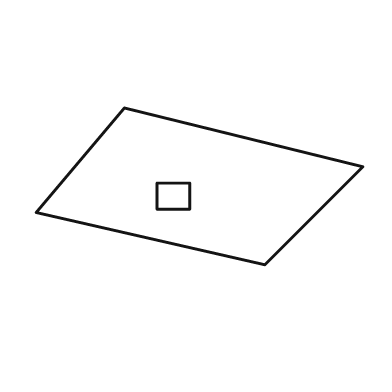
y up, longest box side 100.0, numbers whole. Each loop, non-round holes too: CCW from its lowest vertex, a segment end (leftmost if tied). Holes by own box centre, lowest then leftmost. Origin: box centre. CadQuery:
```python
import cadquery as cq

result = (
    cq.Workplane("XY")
    .moveTo(20.0, -24.0)
    .lineTo(50.0, 6.0)
    .lineTo(-23.0, 24.0)
    .lineTo(-50.0, -8.0)
    .close()
    .moveTo(-13.0, -7.0)
    .lineTo(-3.0, -7.0)
    .lineTo(-3.0, 1.0)
    .lineTo(-13.0, 1.0)
    .close()
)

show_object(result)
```